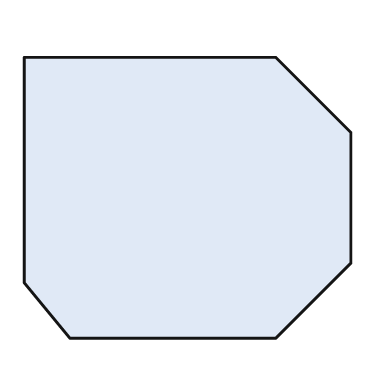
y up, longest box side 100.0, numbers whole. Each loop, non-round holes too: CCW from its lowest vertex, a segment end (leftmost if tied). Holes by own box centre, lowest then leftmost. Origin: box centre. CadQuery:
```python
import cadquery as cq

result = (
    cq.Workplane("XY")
    .moveTo(-36.0, -43.0)
    .lineTo(27.0, -43.0)
    .lineTo(50.0, -20.0)
    .lineTo(50.0, 20.0)
    .lineTo(27.0, 43.0)
    .lineTo(-50.0, 43.0)
    .lineTo(-50.0, -26.0)
    .close()
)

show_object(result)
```